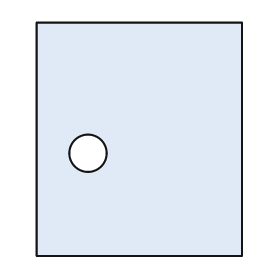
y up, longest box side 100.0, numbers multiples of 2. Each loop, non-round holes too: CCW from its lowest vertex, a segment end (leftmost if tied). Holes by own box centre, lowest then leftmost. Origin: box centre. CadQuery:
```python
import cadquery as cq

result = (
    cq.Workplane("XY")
    .moveTo(-44.0, -50.0)
    .lineTo(44.0, -50.0)
    .lineTo(44.0, 50.0)
    .lineTo(-44.0, 50.0)
    .close()
    .moveTo(-22.0, -6.0)
    .circle(8.0)
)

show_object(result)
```